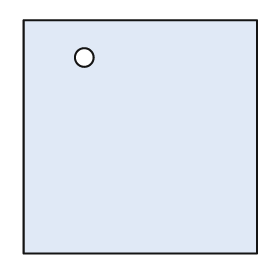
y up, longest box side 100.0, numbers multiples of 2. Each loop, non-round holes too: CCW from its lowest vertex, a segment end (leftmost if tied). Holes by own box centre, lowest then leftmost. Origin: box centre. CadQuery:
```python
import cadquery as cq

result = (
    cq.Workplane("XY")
    .moveTo(-50.0, -50.0)
    .lineTo(50.0, -50.0)
    .lineTo(50.0, 50.0)
    .lineTo(-50.0, 50.0)
    .close()
    .moveTo(-24.0, 34.0)
    .circle(4.0)
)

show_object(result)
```